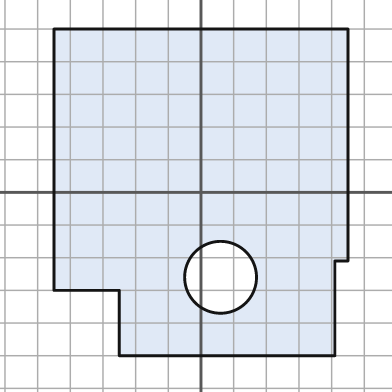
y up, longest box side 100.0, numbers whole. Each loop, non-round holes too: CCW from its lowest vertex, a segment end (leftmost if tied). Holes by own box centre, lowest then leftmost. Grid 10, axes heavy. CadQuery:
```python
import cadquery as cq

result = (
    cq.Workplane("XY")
    .moveTo(-25.0, -50.0)
    .lineTo(41.0, -50.0)
    .lineTo(41.0, -21.0)
    .lineTo(45.0, -21.0)
    .lineTo(45.0, 50.0)
    .lineTo(-45.0, 50.0)
    .lineTo(-45.0, -30.0)
    .lineTo(-25.0, -30.0)
    .close()
    .moveTo(6.0, -26.0)
    .circle(11.0)
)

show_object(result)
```